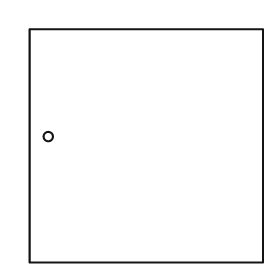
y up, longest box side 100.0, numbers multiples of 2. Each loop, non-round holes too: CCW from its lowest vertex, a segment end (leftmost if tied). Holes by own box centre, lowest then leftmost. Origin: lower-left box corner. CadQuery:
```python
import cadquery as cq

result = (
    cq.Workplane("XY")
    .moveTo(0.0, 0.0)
    .lineTo(100.0, 0.0)
    .lineTo(100.0, 100.0)
    .lineTo(0.0, 100.0)
    .close()
    .moveTo(8.0, 54.0)
    .circle(2.0)
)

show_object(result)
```